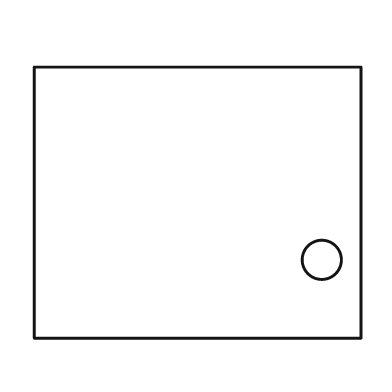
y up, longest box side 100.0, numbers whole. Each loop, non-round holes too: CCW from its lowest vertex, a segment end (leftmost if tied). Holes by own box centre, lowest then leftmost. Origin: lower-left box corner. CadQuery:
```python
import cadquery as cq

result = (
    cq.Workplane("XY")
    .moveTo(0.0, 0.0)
    .lineTo(100.0, 0.0)
    .lineTo(100.0, 83.0)
    .lineTo(0.0, 83.0)
    .close()
    .moveTo(88.0, 24.0)
    .circle(6.0)
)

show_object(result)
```